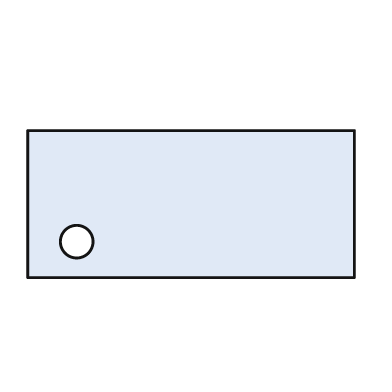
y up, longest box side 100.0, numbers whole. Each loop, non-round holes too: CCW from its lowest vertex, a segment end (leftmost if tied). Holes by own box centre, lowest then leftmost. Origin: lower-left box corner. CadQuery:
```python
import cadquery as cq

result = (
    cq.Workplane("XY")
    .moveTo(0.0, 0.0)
    .lineTo(100.0, 0.0)
    .lineTo(100.0, 45.0)
    .lineTo(0.0, 45.0)
    .close()
    .moveTo(15.0, 11.0)
    .circle(5.0)
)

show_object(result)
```